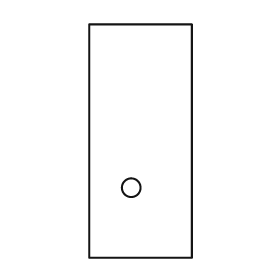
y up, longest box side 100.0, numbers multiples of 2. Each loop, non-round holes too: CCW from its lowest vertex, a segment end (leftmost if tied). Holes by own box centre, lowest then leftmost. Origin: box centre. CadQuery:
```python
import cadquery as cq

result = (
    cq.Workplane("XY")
    .moveTo(-22.0, -50.0)
    .lineTo(22.0, -50.0)
    .lineTo(22.0, 50.0)
    .lineTo(-22.0, 50.0)
    .close()
    .moveTo(-4.0, -20.0)
    .circle(4.0)
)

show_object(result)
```